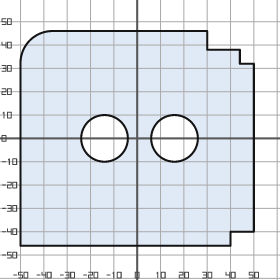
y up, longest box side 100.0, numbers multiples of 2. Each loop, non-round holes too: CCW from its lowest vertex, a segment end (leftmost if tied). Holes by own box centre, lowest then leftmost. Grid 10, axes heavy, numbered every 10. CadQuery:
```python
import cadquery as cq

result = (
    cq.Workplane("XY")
    .moveTo(-50.0, -46.0)
    .lineTo(40.0, -46.0)
    .lineTo(40.0, -40.0)
    .lineTo(50.0, -40.0)
    .lineTo(50.0, 32.0)
    .lineTo(44.0, 32.0)
    .lineTo(44.0, 38.0)
    .lineTo(30.0, 38.0)
    .lineTo(30.0, 46.0)
    .lineTo(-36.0, 46.0)
    .threePointArc((-46.0, 42.0), (-50.0, 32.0))
    .close()
    .moveTo(-14.0, 0.0)
    .circle(10.0)
    .moveTo(16.0, 0.0)
    .circle(10.0)
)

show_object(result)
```